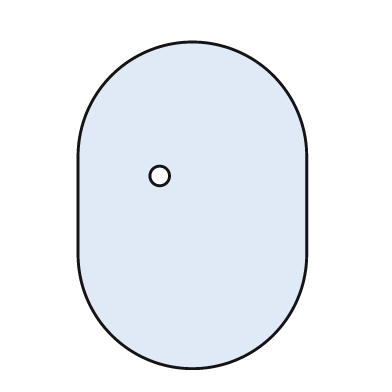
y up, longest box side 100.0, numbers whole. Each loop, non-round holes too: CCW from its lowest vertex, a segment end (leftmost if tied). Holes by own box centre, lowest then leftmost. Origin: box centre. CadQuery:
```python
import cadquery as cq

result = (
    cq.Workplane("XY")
    .moveTo(-35.0, -15.0)
    .threePointArc((0.0, -50.0), (35.0, -15.0))
    .lineTo(35.0, 15.0)
    .threePointArc((0.0, 50.0), (-35.0, 15.0))
    .close()
    .moveTo(-10.0, 9.0)
    .circle(3.0)
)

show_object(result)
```